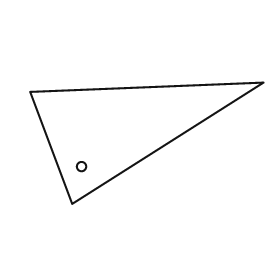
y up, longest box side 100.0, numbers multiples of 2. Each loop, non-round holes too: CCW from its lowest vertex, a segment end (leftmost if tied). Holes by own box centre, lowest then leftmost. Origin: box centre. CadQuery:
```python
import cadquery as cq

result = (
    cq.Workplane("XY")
    .moveTo(-32.0, -26.0)
    .lineTo(50.0, 26.0)
    .lineTo(-50.0, 22.0)
    .close()
    .moveTo(-28.0, -10.0)
    .circle(2.0)
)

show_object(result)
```